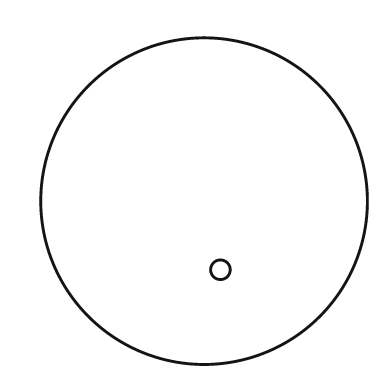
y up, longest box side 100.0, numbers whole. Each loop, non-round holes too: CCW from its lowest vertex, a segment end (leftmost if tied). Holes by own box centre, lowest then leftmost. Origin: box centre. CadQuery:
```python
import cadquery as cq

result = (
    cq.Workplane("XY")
    .moveTo(0.0, 0.0)
    .circle(50.0)
    .moveTo(5.0, -21.0)
    .circle(3.0)
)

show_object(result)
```